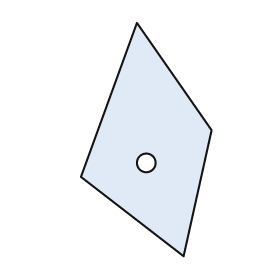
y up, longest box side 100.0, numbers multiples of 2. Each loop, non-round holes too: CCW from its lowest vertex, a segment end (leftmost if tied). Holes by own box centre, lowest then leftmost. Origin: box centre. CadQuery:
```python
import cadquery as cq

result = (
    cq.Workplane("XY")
    .moveTo(16.0, -50.0)
    .lineTo(28.0, 4.0)
    .lineTo(-4.0, 50.0)
    .lineTo(-28.0, -16.0)
    .close()
    .moveTo(0.0, -10.0)
    .circle(4.0)
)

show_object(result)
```